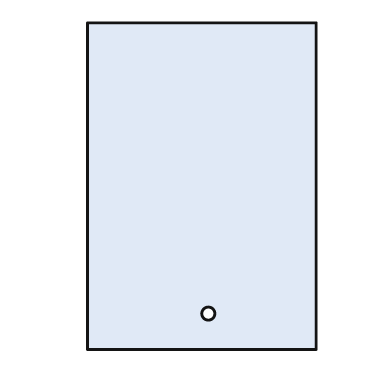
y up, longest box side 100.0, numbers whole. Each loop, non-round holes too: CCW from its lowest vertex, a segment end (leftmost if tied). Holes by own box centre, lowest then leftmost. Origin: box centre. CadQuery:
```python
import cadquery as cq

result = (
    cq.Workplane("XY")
    .moveTo(-35.0, -50.0)
    .lineTo(35.0, -50.0)
    .lineTo(35.0, 50.0)
    .lineTo(-35.0, 50.0)
    .close()
    .moveTo(2.0, -39.0)
    .circle(2.0)
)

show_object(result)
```